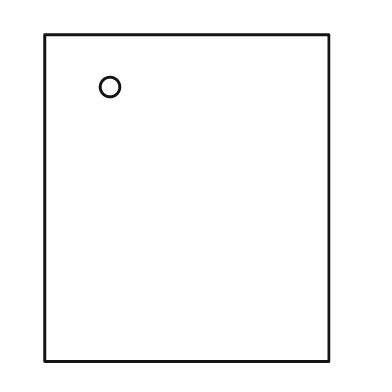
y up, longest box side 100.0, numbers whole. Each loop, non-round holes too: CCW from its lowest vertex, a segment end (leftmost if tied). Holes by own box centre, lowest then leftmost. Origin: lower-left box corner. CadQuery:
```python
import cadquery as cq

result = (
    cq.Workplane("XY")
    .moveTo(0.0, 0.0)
    .lineTo(87.0, 0.0)
    .lineTo(87.0, 100.0)
    .lineTo(0.0, 100.0)
    .close()
    .moveTo(20.0, 84.0)
    .circle(3.0)
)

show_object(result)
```